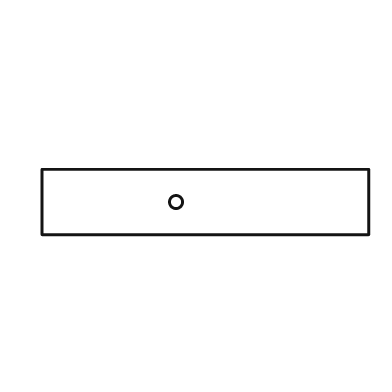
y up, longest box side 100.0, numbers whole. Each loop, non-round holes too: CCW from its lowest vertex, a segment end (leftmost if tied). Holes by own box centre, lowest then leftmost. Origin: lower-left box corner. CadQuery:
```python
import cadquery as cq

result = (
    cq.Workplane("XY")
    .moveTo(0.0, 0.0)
    .lineTo(100.0, 0.0)
    .lineTo(100.0, 20.0)
    .lineTo(0.0, 20.0)
    .close()
    .moveTo(41.0, 10.0)
    .circle(2.0)
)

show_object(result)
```